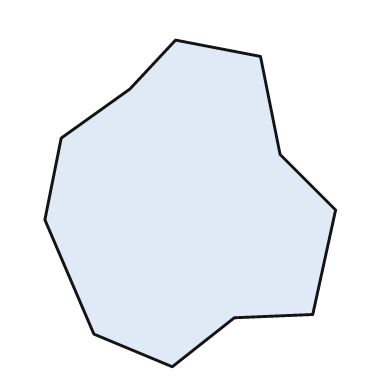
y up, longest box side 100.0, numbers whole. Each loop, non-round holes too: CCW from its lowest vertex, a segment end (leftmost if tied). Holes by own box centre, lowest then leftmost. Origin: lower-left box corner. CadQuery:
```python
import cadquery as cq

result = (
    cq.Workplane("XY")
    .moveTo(39.0, 0.0)
    .lineTo(58.0, 15.0)
    .lineTo(82.0, 16.0)
    .lineTo(89.0, 48.0)
    .lineTo(72.0, 65.0)
    .lineTo(66.0, 95.0)
    .lineTo(40.0, 100.0)
    .lineTo(26.0, 85.0)
    .lineTo(5.0, 70.0)
    .lineTo(0.0, 45.0)
    .lineTo(15.0, 10.0)
    .close()
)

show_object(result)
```